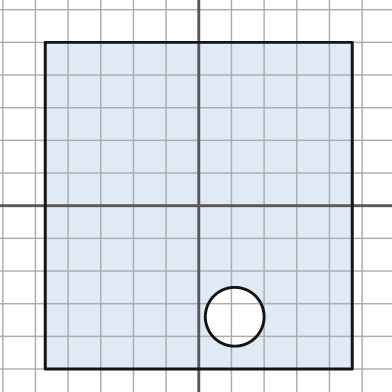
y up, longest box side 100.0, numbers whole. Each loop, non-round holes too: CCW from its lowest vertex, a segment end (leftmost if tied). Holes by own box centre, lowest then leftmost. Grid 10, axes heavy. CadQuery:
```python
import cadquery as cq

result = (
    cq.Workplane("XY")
    .moveTo(-47.0, -50.0)
    .lineTo(47.0, -50.0)
    .lineTo(47.0, 50.0)
    .lineTo(-47.0, 50.0)
    .close()
    .moveTo(11.0, -34.0)
    .circle(9.0)
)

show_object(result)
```